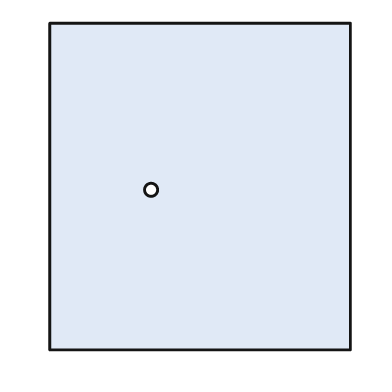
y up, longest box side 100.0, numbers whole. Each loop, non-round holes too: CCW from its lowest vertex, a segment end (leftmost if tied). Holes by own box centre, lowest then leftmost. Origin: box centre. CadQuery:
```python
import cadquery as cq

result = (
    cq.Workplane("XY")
    .moveTo(-46.0, -50.0)
    .lineTo(46.0, -50.0)
    .lineTo(46.0, 50.0)
    .lineTo(-46.0, 50.0)
    .close()
    .moveTo(-15.0, -1.0)
    .circle(2.0)
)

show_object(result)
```